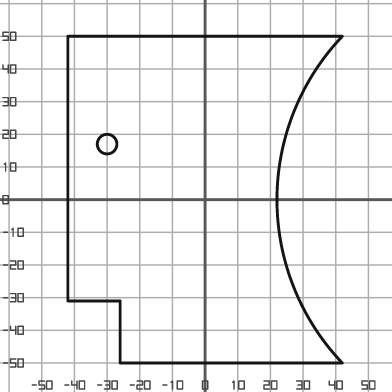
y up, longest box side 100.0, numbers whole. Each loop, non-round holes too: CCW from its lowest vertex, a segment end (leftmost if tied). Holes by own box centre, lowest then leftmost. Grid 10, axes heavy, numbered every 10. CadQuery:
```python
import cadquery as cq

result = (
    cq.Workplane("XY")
    .moveTo(-26.0, -50.0)
    .lineTo(42.0, -50.0)
    .threePointArc((22.0, 0.0), (42.0, 50.0))
    .lineTo(-42.0, 50.0)
    .lineTo(-42.0, -31.0)
    .lineTo(-26.0, -31.0)
    .close()
    .moveTo(-30.0, 17.0)
    .circle(3.0)
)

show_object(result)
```